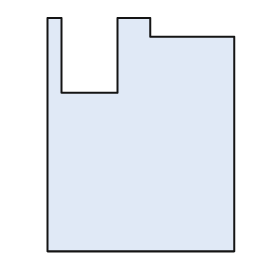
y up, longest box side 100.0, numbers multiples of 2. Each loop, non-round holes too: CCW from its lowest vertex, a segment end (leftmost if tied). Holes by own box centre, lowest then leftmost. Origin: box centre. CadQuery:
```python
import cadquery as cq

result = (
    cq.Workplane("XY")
    .moveTo(-40.0, -50.0)
    .lineTo(40.0, -50.0)
    .lineTo(40.0, 42.0)
    .lineTo(4.0, 42.0)
    .lineTo(4.0, 50.0)
    .lineTo(-10.0, 50.0)
    .lineTo(-10.0, 18.0)
    .lineTo(-34.0, 18.0)
    .lineTo(-34.0, 50.0)
    .lineTo(-40.0, 50.0)
    .close()
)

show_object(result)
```